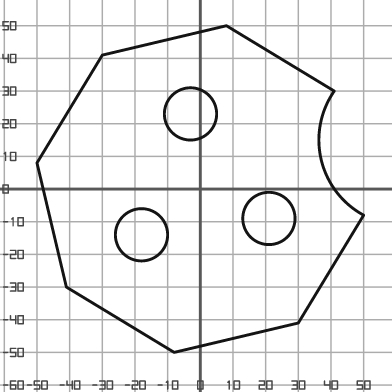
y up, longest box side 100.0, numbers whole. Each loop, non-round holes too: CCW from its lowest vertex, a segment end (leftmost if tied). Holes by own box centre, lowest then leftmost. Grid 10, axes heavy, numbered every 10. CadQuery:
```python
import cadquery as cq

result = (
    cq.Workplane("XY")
    .moveTo(-8.0, -50.0)
    .lineTo(30.0, -41.0)
    .lineTo(50.0, -8.0)
    .threePointArc((37.0, 9.0), (41.0, 30.0))
    .lineTo(8.0, 50.0)
    .lineTo(-30.0, 41.0)
    .lineTo(-50.0, 8.0)
    .lineTo(-41.0, -30.0)
    .close()
    .moveTo(-18.0, -14.0)
    .circle(8.0)
    .moveTo(21.0, -9.0)
    .circle(8.0)
    .moveTo(-3.0, 23.0)
    .circle(8.0)
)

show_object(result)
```